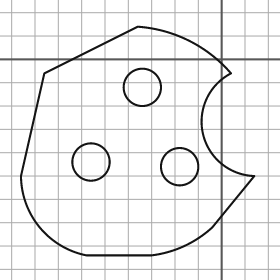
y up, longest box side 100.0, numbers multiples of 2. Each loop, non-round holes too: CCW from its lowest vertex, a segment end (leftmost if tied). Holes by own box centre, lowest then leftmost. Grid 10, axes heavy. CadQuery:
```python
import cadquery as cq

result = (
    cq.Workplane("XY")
    .moveTo(-58.0, -84.0)
    .lineTo(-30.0, -84.0)
    .threePointArc((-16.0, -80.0), (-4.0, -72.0))
    .lineTo(14.0, -50.0)
    .threePointArc((-8.0, -32.0), (4.0, -6.0))
    .threePointArc((-14.0, 8.0), (-36.0, 14.0))
    .lineTo(-76.0, -6.0)
    .lineTo(-86.0, -50.0)
    .threePointArc((-78.0, -72.0), (-58.0, -84.0))
    .close()
    .moveTo(-18.0, -46.0)
    .circle(8.0)
    .moveTo(-56.0, -44.0)
    .circle(8.0)
    .moveTo(-34.0, -12.0)
    .circle(8.0)
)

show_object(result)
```